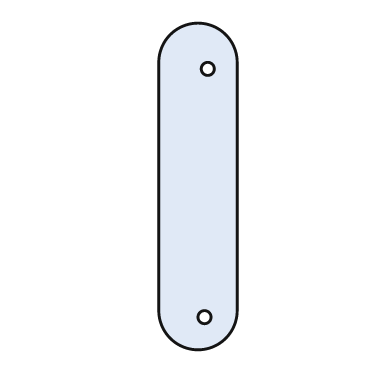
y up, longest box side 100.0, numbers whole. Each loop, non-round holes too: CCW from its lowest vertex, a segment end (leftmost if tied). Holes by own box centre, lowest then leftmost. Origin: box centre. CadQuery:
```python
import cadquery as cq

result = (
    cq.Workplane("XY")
    .moveTo(-12.0, -38.0)
    .threePointArc((0.0, -50.0), (12.0, -38.0))
    .lineTo(12.0, 38.0)
    .threePointArc((0.0, 50.0), (-12.0, 38.0))
    .close()
    .moveTo(2.0, -40.0)
    .circle(2.0)
    .moveTo(3.0, 36.0)
    .circle(2.0)
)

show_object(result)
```